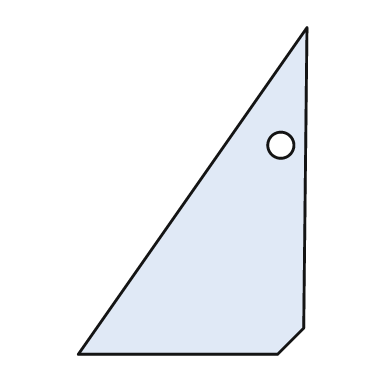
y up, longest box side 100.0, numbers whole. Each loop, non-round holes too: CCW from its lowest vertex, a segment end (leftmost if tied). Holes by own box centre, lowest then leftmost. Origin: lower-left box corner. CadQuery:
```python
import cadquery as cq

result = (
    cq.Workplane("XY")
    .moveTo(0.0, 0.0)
    .lineTo(61.0, 0.0)
    .lineTo(69.0, 8.0)
    .lineTo(70.0, 100.0)
    .close()
    .moveTo(62.0, 64.0)
    .circle(4.0)
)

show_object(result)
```